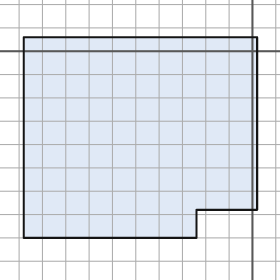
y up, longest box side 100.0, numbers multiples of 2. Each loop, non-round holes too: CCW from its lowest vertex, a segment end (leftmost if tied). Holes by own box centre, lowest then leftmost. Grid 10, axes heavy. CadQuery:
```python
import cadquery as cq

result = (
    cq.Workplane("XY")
    .moveTo(-98.0, -80.0)
    .lineTo(-24.0, -80.0)
    .lineTo(-24.0, -68.0)
    .lineTo(2.0, -68.0)
    .lineTo(2.0, 6.0)
    .lineTo(-98.0, 6.0)
    .close()
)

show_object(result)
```